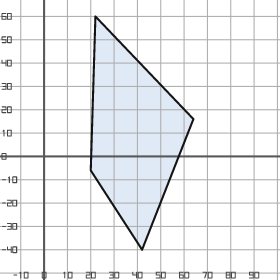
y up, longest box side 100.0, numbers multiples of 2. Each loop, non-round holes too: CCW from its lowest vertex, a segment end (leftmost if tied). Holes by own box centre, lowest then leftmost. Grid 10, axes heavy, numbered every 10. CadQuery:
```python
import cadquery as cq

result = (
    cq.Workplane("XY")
    .moveTo(42.0, -40.0)
    .lineTo(64.0, 16.0)
    .lineTo(22.0, 60.0)
    .lineTo(20.0, -6.0)
    .close()
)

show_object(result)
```